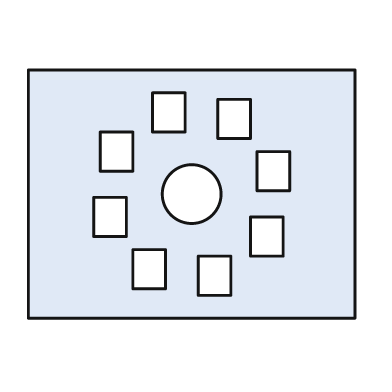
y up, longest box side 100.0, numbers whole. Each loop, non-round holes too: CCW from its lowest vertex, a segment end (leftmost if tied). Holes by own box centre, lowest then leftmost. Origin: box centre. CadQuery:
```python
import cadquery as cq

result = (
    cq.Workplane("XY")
    .moveTo(-50.0, -38.0)
    .lineTo(50.0, -38.0)
    .lineTo(50.0, 38.0)
    .lineTo(-50.0, 38.0)
    .close()
    .moveTo(2.0, -31.0)
    .lineTo(12.0, -31.0)
    .lineTo(12.0, -19.0)
    .lineTo(2.0, -19.0)
    .close()
    .moveTo(-18.0, -29.0)
    .lineTo(-8.0, -29.0)
    .lineTo(-8.0, -17.0)
    .lineTo(-18.0, -17.0)
    .close()
    .moveTo(18.0, -19.0)
    .lineTo(28.0, -19.0)
    .lineTo(28.0, -7.0)
    .lineTo(18.0, -7.0)
    .close()
    .moveTo(-30.0, -13.0)
    .lineTo(-20.0, -13.0)
    .lineTo(-20.0, -1.0)
    .lineTo(-30.0, -1.0)
    .close()
    .moveTo(0.0, 0.0)
    .circle(9.0)
    .moveTo(20.0, 1.0)
    .lineTo(30.0, 1.0)
    .lineTo(30.0, 13.0)
    .lineTo(20.0, 13.0)
    .close()
    .moveTo(-28.0, 7.0)
    .lineTo(-18.0, 7.0)
    .lineTo(-18.0, 19.0)
    .lineTo(-28.0, 19.0)
    .close()
    .moveTo(8.0, 17.0)
    .lineTo(18.0, 17.0)
    .lineTo(18.0, 29.0)
    .lineTo(8.0, 29.0)
    .close()
    .moveTo(-12.0, 19.0)
    .lineTo(-2.0, 19.0)
    .lineTo(-2.0, 31.0)
    .lineTo(-12.0, 31.0)
    .close()
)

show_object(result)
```